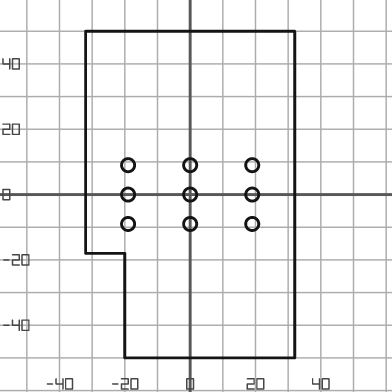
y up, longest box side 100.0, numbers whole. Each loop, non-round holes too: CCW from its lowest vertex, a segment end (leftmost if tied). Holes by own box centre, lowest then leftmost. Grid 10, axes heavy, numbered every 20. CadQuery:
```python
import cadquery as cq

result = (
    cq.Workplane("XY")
    .moveTo(-20.0, -50.0)
    .lineTo(32.0, -50.0)
    .lineTo(32.0, 50.0)
    .lineTo(-32.0, 50.0)
    .lineTo(-32.0, -18.0)
    .lineTo(-20.0, -18.0)
    .close()
    .moveTo(-19.0, -9.0)
    .circle(2.0)
    .moveTo(0.0, -9.0)
    .circle(2.0)
    .moveTo(19.0, -9.0)
    .circle(2.0)
    .moveTo(-19.0, 0.0)
    .circle(2.0)
    .moveTo(0.0, 0.0)
    .circle(2.0)
    .moveTo(19.0, 0.0)
    .circle(2.0)
    .moveTo(-19.0, 9.0)
    .circle(2.0)
    .moveTo(0.0, 9.0)
    .circle(2.0)
    .moveTo(19.0, 9.0)
    .circle(2.0)
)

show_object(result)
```